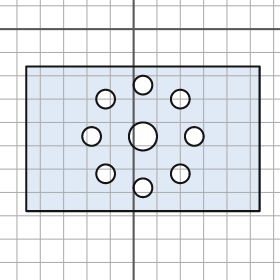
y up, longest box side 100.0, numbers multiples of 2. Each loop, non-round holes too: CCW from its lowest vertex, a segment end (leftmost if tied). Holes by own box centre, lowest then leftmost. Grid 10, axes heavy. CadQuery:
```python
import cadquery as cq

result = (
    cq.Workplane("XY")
    .moveTo(-46.0, -78.0)
    .lineTo(54.0, -78.0)
    .lineTo(54.0, -16.0)
    .lineTo(-46.0, -16.0)
    .close()
    .moveTo(4.0, -68.0)
    .circle(4.0)
    .moveTo(-12.0, -62.0)
    .circle(4.0)
    .moveTo(20.0, -62.0)
    .circle(4.0)
    .moveTo(-18.0, -46.0)
    .circle(4.0)
    .moveTo(4.0, -46.0)
    .circle(6.0)
    .moveTo(26.0, -46.0)
    .circle(4.0)
    .moveTo(-12.0, -30.0)
    .circle(4.0)
    .moveTo(20.0, -30.0)
    .circle(4.0)
    .moveTo(4.0, -24.0)
    .circle(4.0)
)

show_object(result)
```